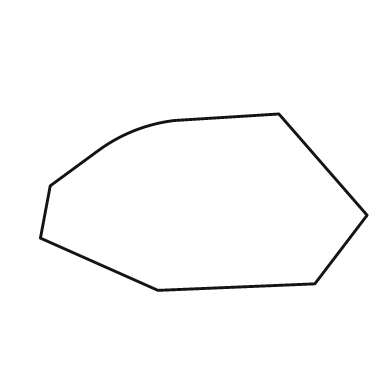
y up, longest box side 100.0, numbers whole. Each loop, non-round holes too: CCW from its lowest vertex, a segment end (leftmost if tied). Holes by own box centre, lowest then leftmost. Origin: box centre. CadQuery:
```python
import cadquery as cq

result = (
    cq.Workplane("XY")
    .moveTo(-14.0, -27.0)
    .lineTo(34.0, -25.0)
    .lineTo(50.0, -4.0)
    .lineTo(23.0, 27.0)
    .lineTo(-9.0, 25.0)
    .threePointArc((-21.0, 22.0), (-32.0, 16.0))
    .lineTo(-47.0, 5.0)
    .lineTo(-50.0, -11.0)
    .close()
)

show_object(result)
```